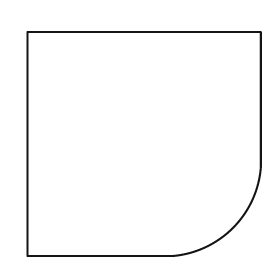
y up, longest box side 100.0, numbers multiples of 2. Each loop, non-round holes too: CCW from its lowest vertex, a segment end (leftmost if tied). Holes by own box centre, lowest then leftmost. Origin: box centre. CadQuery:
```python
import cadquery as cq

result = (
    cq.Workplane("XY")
    .moveTo(-50.0, -48.0)
    .lineTo(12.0, -48.0)
    .threePointArc((38.0, -36.0), (50.0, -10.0))
    .lineTo(50.0, 48.0)
    .lineTo(-50.0, 48.0)
    .close()
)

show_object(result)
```